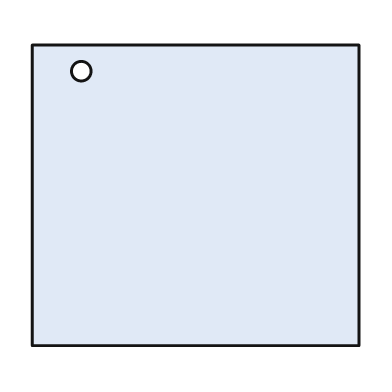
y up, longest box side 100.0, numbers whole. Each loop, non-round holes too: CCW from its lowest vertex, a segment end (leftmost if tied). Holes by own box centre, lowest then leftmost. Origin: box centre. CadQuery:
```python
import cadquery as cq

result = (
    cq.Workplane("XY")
    .moveTo(-50.0, -46.0)
    .lineTo(50.0, -46.0)
    .lineTo(50.0, 46.0)
    .lineTo(-50.0, 46.0)
    .close()
    .moveTo(-35.0, 38.0)
    .circle(3.0)
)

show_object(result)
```